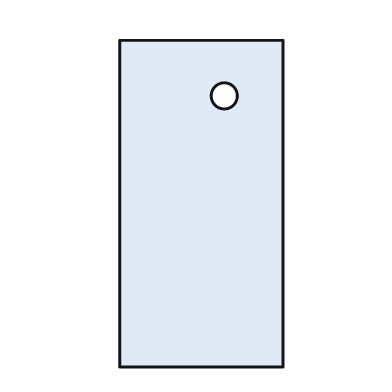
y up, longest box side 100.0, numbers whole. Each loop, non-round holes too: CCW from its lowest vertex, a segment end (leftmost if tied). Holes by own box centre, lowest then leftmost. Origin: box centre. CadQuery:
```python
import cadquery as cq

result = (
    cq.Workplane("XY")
    .moveTo(-25.0, -50.0)
    .lineTo(25.0, -50.0)
    .lineTo(25.0, 50.0)
    .lineTo(-25.0, 50.0)
    .close()
    .moveTo(7.0, 33.0)
    .circle(4.0)
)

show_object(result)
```